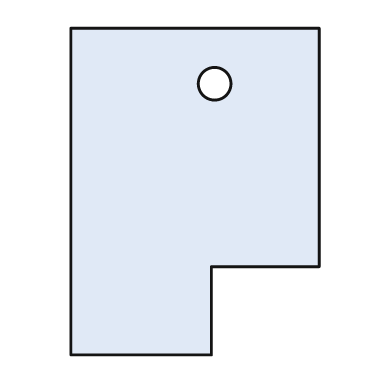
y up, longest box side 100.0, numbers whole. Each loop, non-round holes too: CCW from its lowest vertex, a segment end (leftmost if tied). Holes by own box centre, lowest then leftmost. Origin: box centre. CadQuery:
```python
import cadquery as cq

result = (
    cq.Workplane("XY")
    .moveTo(-38.0, -50.0)
    .lineTo(5.0, -50.0)
    .lineTo(5.0, -23.0)
    .lineTo(38.0, -23.0)
    .lineTo(38.0, 50.0)
    .lineTo(-38.0, 50.0)
    .close()
    .moveTo(6.0, 33.0)
    .circle(5.0)
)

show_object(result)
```